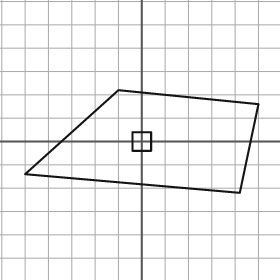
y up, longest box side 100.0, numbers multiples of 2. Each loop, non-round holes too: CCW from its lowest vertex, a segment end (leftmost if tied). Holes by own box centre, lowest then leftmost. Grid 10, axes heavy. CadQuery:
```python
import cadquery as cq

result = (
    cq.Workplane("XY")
    .moveTo(42.0, -22.0)
    .lineTo(50.0, 16.0)
    .lineTo(-10.0, 22.0)
    .lineTo(-50.0, -14.0)
    .close()
    .moveTo(-4.0, -4.0)
    .lineTo(4.0, -4.0)
    .lineTo(4.0, 4.0)
    .lineTo(-4.0, 4.0)
    .close()
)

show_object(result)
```